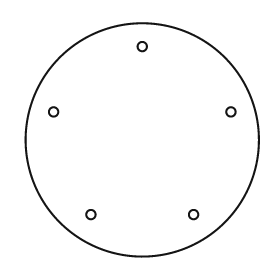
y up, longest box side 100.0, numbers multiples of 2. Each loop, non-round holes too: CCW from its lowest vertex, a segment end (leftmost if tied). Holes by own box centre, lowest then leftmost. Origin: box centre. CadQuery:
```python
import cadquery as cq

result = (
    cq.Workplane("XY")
    .moveTo(0.0, 0.0)
    .circle(50.0)
    .moveTo(-22.0, -32.0)
    .circle(2.0)
    .moveTo(22.0, -32.0)
    .circle(2.0)
    .moveTo(-38.0, 12.0)
    .circle(2.0)
    .moveTo(38.0, 12.0)
    .circle(2.0)
    .moveTo(0.0, 40.0)
    .circle(2.0)
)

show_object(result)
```